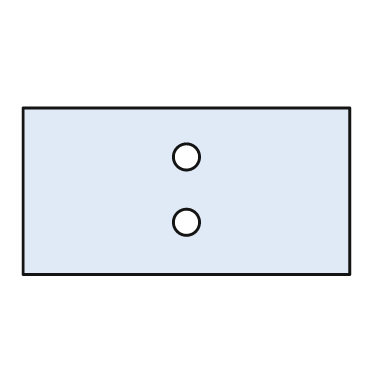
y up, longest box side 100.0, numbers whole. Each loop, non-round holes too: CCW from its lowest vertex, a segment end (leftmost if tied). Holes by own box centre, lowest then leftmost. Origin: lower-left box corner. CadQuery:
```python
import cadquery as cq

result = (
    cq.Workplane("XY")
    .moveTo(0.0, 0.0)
    .lineTo(100.0, 0.0)
    .lineTo(100.0, 51.0)
    .lineTo(0.0, 51.0)
    .close()
    .moveTo(50.0, 16.0)
    .circle(4.0)
    .moveTo(50.0, 36.0)
    .circle(4.0)
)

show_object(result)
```